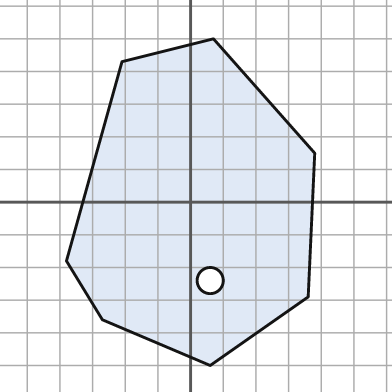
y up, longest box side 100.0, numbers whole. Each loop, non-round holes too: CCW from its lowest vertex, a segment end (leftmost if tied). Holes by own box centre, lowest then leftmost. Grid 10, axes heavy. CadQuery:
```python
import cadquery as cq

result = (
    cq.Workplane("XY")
    .moveTo(6.0, -50.0)
    .lineTo(36.0, -29.0)
    .lineTo(38.0, 15.0)
    .lineTo(7.0, 50.0)
    .lineTo(-21.0, 43.0)
    .lineTo(-38.0, -18.0)
    .lineTo(-27.0, -36.0)
    .close()
    .moveTo(6.0, -24.0)
    .circle(4.0)
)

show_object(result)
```